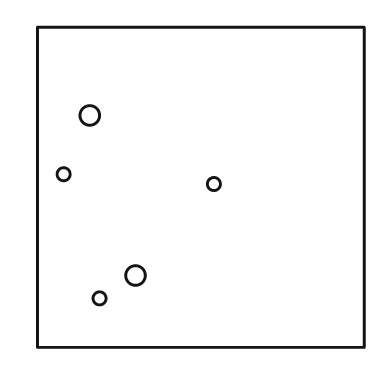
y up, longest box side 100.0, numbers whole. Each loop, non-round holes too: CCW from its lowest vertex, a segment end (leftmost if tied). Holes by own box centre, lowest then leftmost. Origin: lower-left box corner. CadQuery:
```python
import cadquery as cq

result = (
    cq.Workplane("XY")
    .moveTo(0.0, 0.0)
    .lineTo(100.0, 0.0)
    .lineTo(100.0, 98.0)
    .lineTo(0.0, 98.0)
    .close()
    .moveTo(19.0, 15.0)
    .circle(2.0)
    .moveTo(30.0, 22.0)
    .circle(3.0)
    .moveTo(54.0, 50.0)
    .circle(2.0)
    .moveTo(8.0, 53.0)
    .circle(2.0)
    .moveTo(16.0, 71.0)
    .circle(3.0)
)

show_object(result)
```